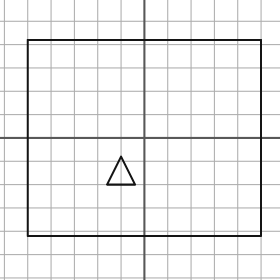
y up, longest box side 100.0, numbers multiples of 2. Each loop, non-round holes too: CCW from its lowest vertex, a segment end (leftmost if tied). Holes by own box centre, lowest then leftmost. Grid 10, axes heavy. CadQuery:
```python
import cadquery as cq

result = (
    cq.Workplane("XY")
    .moveTo(-50.0, -42.0)
    .lineTo(50.0, -42.0)
    .lineTo(50.0, 42.0)
    .lineTo(-50.0, 42.0)
    .close()
    .moveTo(-16.0, -20.0)
    .lineTo(-4.0, -20.0)
    .lineTo(-10.0, -8.0)
    .close()
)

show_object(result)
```